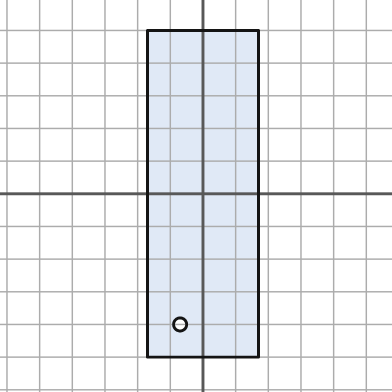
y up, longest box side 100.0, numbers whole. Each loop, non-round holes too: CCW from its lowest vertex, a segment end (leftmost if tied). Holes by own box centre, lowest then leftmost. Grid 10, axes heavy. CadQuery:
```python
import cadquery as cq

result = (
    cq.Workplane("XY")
    .moveTo(-17.0, -50.0)
    .lineTo(17.0, -50.0)
    .lineTo(17.0, 50.0)
    .lineTo(-17.0, 50.0)
    .close()
    .moveTo(-7.0, -40.0)
    .circle(2.0)
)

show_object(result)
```